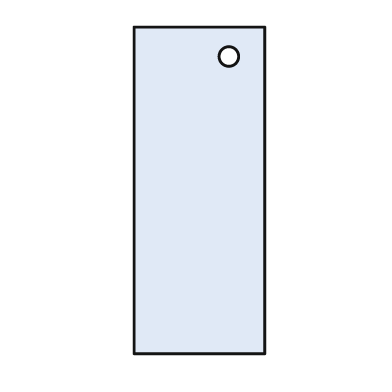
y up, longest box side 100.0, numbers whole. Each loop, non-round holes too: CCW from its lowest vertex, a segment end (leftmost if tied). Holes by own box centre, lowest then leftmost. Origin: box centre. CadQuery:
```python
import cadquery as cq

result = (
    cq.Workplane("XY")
    .moveTo(-20.0, -50.0)
    .lineTo(20.0, -50.0)
    .lineTo(20.0, 50.0)
    .lineTo(-20.0, 50.0)
    .close()
    .moveTo(9.0, 41.0)
    .circle(3.0)
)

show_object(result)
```